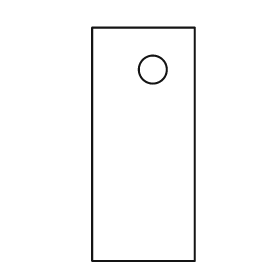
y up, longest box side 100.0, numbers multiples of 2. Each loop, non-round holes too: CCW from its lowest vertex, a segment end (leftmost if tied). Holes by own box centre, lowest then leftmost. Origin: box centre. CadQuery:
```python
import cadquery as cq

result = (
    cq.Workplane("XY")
    .moveTo(-22.0, -50.0)
    .lineTo(22.0, -50.0)
    .lineTo(22.0, 50.0)
    .lineTo(-22.0, 50.0)
    .close()
    .moveTo(4.0, 32.0)
    .circle(6.0)
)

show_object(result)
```